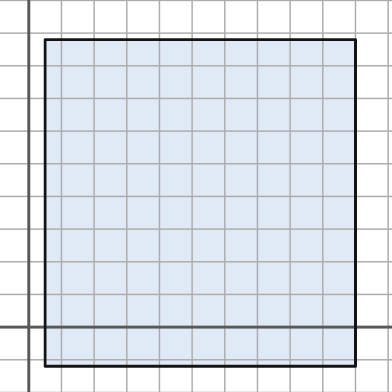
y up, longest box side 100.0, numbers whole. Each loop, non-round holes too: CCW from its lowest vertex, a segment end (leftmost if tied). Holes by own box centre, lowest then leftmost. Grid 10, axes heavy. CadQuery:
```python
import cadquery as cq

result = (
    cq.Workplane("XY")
    .moveTo(5.0, -12.0)
    .lineTo(100.0, -12.0)
    .lineTo(100.0, 88.0)
    .lineTo(5.0, 88.0)
    .close()
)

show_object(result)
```